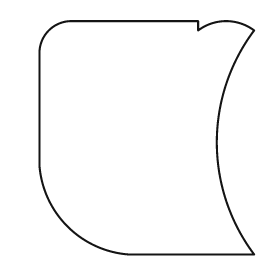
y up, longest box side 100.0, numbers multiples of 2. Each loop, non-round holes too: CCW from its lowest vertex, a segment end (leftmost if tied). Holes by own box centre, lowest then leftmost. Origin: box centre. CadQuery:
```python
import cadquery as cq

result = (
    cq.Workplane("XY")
    .moveTo(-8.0, -50.0)
    .lineTo(46.0, -50.0)
    .threePointArc((30.0, -2.0), (46.0, 46.0))
    .threePointArc((34.0, 50.0), (22.0, 46.0))
    .lineTo(22.0, 50.0)
    .lineTo(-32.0, 50.0)
    .threePointArc((-42.0, 46.0), (-46.0, 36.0))
    .lineTo(-46.0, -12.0)
    .threePointArc((-34.0, -38.0), (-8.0, -50.0))
    .close()
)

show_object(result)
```